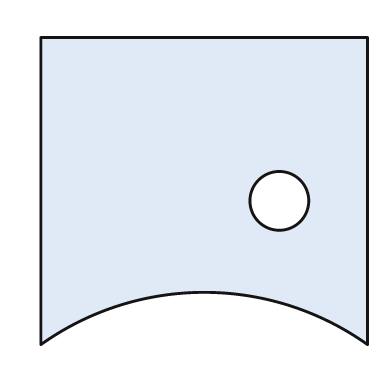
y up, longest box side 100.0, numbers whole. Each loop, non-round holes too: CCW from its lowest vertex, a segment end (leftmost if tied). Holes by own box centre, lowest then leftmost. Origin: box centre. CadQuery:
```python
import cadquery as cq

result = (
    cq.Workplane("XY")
    .moveTo(-50.0, -47.0)
    .threePointArc((0.0, -31.0), (50.0, -47.0))
    .lineTo(50.0, 47.0)
    .lineTo(-50.0, 47.0)
    .close()
    .moveTo(23.0, -3.0)
    .circle(9.0)
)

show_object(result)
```